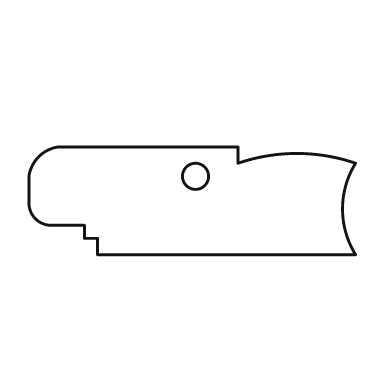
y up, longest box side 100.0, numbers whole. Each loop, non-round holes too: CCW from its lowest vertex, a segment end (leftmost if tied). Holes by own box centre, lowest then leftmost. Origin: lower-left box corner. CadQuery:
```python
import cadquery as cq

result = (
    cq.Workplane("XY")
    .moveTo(21.0, 0.0)
    .lineTo(100.0, 0.0)
    .threePointArc((96.0, 14.0), (100.0, 28.0))
    .threePointArc((82.0, 31.0), (64.0, 28.0))
    .lineTo(64.0, 33.0)
    .lineTo(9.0, 33.0)
    .threePointArc((3.0, 30.0), (0.0, 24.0))
    .lineTo(0.0, 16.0)
    .threePointArc((2.0, 11.0), (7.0, 9.0))
    .lineTo(17.0, 9.0)
    .lineTo(17.0, 5.0)
    .lineTo(21.0, 5.0)
    .close()
    .moveTo(51.0, 24.0)
    .circle(4.0)
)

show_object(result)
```